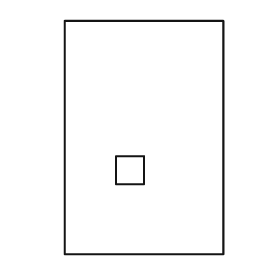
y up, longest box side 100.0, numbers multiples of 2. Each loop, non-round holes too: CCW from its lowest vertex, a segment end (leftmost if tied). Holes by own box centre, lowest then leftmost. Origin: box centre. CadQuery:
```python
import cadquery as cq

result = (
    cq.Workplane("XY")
    .moveTo(-34.0, -50.0)
    .lineTo(34.0, -50.0)
    .lineTo(34.0, 50.0)
    .lineTo(-34.0, 50.0)
    .close()
    .moveTo(-12.0, -20.0)
    .lineTo(0.0, -20.0)
    .lineTo(0.0, -8.0)
    .lineTo(-12.0, -8.0)
    .close()
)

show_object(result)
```